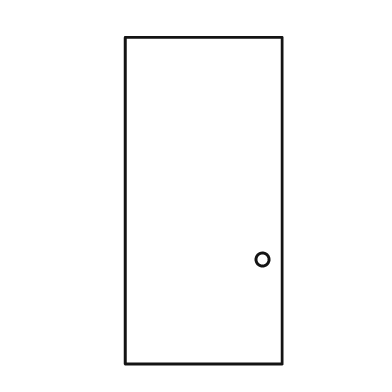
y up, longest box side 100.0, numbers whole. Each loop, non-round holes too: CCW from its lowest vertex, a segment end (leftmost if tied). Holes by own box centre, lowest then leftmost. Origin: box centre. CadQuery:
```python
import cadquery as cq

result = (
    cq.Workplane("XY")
    .moveTo(-24.0, -50.0)
    .lineTo(24.0, -50.0)
    .lineTo(24.0, 50.0)
    .lineTo(-24.0, 50.0)
    .close()
    .moveTo(18.0, -18.0)
    .circle(2.0)
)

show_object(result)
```